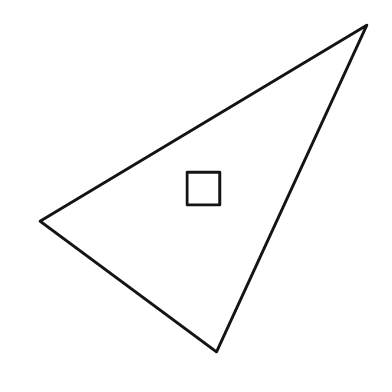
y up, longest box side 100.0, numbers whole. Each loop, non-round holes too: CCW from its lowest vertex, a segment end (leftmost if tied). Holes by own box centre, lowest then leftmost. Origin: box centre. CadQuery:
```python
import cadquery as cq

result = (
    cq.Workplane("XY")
    .moveTo(4.0, -50.0)
    .lineTo(50.0, 50.0)
    .lineTo(-50.0, -10.0)
    .close()
    .moveTo(-5.0, -5.0)
    .lineTo(5.0, -5.0)
    .lineTo(5.0, 5.0)
    .lineTo(-5.0, 5.0)
    .close()
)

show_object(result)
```